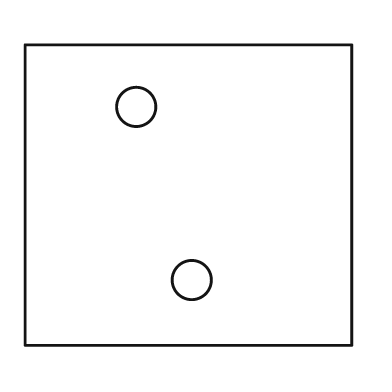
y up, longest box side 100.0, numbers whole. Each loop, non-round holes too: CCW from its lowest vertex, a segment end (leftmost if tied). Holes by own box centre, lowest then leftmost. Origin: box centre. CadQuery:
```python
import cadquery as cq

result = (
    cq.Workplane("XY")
    .moveTo(-50.0, -46.0)
    .lineTo(50.0, -46.0)
    .lineTo(50.0, 46.0)
    .lineTo(-50.0, 46.0)
    .close()
    .moveTo(1.0, -26.0)
    .circle(6.0)
    .moveTo(-16.0, 27.0)
    .circle(6.0)
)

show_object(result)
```